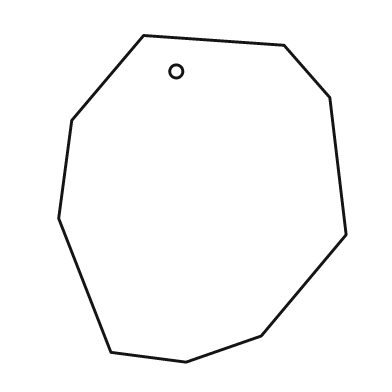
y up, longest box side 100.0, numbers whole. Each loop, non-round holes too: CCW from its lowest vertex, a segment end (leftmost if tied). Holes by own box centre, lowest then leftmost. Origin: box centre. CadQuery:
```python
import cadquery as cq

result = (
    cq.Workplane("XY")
    .moveTo(-5.0, -50.0)
    .lineTo(18.0, -42.0)
    .lineTo(44.0, -11.0)
    .lineTo(39.0, 31.0)
    .lineTo(25.0, 47.0)
    .lineTo(-18.0, 50.0)
    .lineTo(-40.0, 24.0)
    .lineTo(-44.0, -6.0)
    .lineTo(-28.0, -47.0)
    .close()
    .moveTo(-8.0, 39.0)
    .circle(2.0)
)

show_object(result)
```